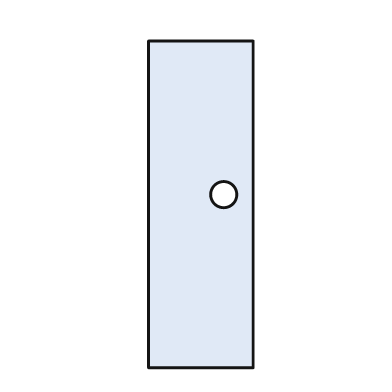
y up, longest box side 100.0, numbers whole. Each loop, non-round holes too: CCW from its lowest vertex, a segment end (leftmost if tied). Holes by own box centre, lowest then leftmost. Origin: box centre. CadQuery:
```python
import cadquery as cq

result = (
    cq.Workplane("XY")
    .moveTo(-16.0, -50.0)
    .lineTo(16.0, -50.0)
    .lineTo(16.0, 50.0)
    .lineTo(-16.0, 50.0)
    .close()
    .moveTo(7.0, 3.0)
    .circle(4.0)
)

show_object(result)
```